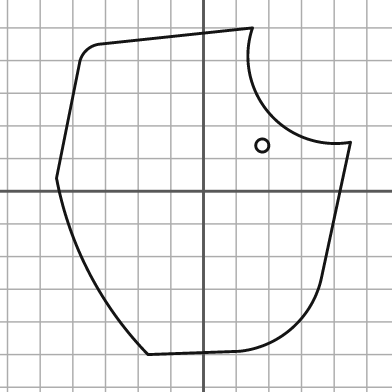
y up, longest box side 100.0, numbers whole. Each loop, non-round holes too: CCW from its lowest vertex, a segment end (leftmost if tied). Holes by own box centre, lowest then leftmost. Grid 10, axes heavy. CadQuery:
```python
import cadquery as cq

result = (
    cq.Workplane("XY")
    .moveTo(-17.0, -50.0)
    .lineTo(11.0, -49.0)
    .threePointArc((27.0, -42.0), (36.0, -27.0))
    .lineTo(45.0, 15.0)
    .threePointArc((20.0, 24.0), (15.0, 50.0))
    .lineTo(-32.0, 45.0)
    .threePointArc((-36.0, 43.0), (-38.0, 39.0))
    .lineTo(-45.0, 4.0)
    .threePointArc((-35.0, -25.0), (-17.0, -50.0))
    .close()
    .moveTo(18.0, 14.0)
    .circle(2.0)
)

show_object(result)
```